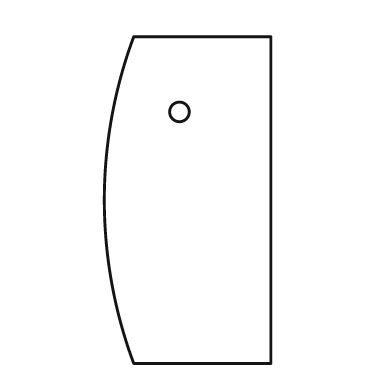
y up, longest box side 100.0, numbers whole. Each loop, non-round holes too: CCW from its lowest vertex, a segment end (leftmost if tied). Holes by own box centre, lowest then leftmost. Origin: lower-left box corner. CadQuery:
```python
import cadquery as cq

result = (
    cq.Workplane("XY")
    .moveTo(9.0, 0.0)
    .lineTo(51.0, 0.0)
    .lineTo(51.0, 100.0)
    .lineTo(9.0, 100.0)
    .threePointArc((0.0, 50.0), (9.0, 0.0))
    .close()
    .moveTo(23.0, 77.0)
    .circle(3.0)
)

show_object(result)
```